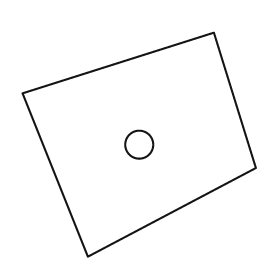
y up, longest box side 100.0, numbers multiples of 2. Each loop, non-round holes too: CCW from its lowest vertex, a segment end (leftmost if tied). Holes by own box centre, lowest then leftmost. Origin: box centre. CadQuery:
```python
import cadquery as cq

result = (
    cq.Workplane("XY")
    .moveTo(-22.0, -48.0)
    .lineTo(50.0, -10.0)
    .lineTo(32.0, 48.0)
    .lineTo(-50.0, 22.0)
    .close()
    .moveTo(0.0, 0.0)
    .circle(6.0)
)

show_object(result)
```